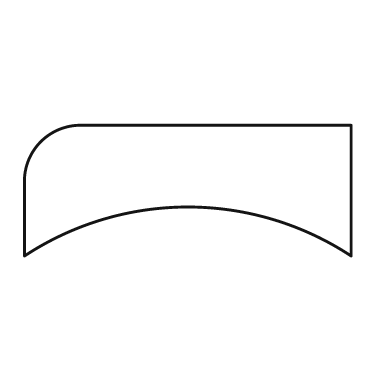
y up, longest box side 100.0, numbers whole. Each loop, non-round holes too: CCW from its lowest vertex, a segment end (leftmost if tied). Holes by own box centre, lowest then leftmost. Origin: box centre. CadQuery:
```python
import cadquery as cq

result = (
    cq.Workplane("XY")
    .moveTo(-50.0, -20.0)
    .threePointArc((0.0, -5.0), (50.0, -20.0))
    .lineTo(50.0, 20.0)
    .lineTo(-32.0, 20.0)
    .threePointArc((-45.0, 15.0), (-50.0, 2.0))
    .close()
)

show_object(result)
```